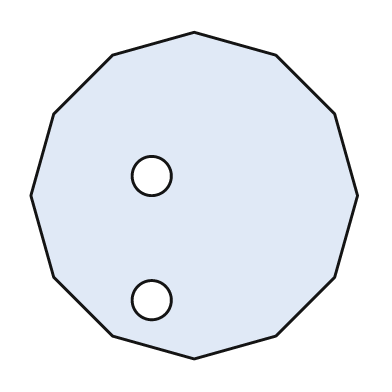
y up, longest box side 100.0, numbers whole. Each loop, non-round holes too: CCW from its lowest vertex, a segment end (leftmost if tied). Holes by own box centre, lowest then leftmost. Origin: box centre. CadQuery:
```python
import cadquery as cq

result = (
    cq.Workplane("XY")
    .moveTo(0.0, -50.0)
    .lineTo(25.0, -43.0)
    .lineTo(43.0, -25.0)
    .lineTo(50.0, 0.0)
    .lineTo(43.0, 25.0)
    .lineTo(25.0, 43.0)
    .lineTo(0.0, 50.0)
    .lineTo(-25.0, 43.0)
    .lineTo(-43.0, 25.0)
    .lineTo(-50.0, 0.0)
    .lineTo(-43.0, -25.0)
    .lineTo(-25.0, -43.0)
    .close()
    .moveTo(-13.0, -32.0)
    .circle(6.0)
    .moveTo(-13.0, 6.0)
    .circle(6.0)
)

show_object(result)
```